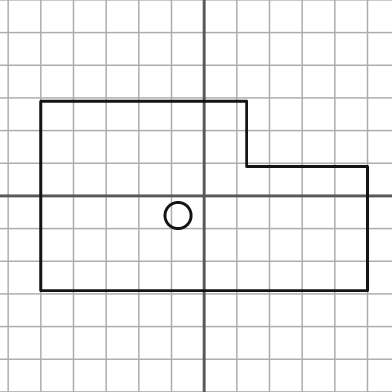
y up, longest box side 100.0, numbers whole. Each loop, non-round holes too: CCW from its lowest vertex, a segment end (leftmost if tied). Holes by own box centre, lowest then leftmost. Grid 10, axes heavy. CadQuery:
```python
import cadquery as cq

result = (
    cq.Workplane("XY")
    .moveTo(-50.0, -29.0)
    .lineTo(50.0, -29.0)
    .lineTo(50.0, 9.0)
    .lineTo(13.0, 9.0)
    .lineTo(13.0, 29.0)
    .lineTo(-50.0, 29.0)
    .close()
    .moveTo(-8.0, -6.0)
    .circle(4.0)
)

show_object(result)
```